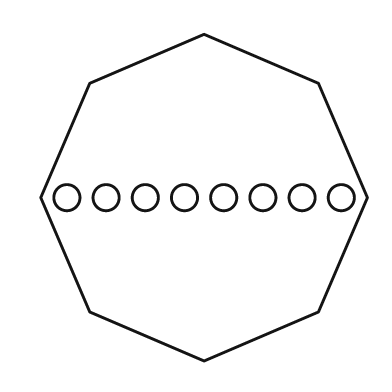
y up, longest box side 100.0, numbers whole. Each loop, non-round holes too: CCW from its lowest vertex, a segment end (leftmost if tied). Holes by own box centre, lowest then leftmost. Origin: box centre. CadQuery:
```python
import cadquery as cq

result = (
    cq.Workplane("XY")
    .moveTo(0.0, -50.0)
    .lineTo(35.0, -35.0)
    .lineTo(50.0, 0.0)
    .lineTo(35.0, 35.0)
    .lineTo(0.0, 50.0)
    .lineTo(-35.0, 35.0)
    .lineTo(-50.0, 0.0)
    .lineTo(-35.0, -35.0)
    .close()
    .moveTo(-42.0, 0.0)
    .circle(4.0)
    .moveTo(-30.0, 0.0)
    .circle(4.0)
    .moveTo(-18.0, 0.0)
    .circle(4.0)
    .moveTo(-6.0, 0.0)
    .circle(4.0)
    .moveTo(6.0, 0.0)
    .circle(4.0)
    .moveTo(18.0, 0.0)
    .circle(4.0)
    .moveTo(30.0, 0.0)
    .circle(4.0)
    .moveTo(42.0, 0.0)
    .circle(4.0)
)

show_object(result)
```